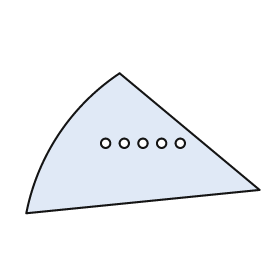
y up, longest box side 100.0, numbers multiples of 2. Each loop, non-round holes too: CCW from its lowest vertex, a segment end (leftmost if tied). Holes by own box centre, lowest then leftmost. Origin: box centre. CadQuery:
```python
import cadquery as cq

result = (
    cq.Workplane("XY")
    .moveTo(-50.0, -30.0)
    .lineTo(50.0, -20.0)
    .lineTo(-10.0, 30.0)
    .threePointArc((-36.0, 4.0), (-50.0, -30.0))
    .close()
    .moveTo(-16.0, 0.0)
    .circle(2.0)
    .moveTo(-8.0, 0.0)
    .circle(2.0)
    .moveTo(0.0, 0.0)
    .circle(2.0)
    .moveTo(8.0, 0.0)
    .circle(2.0)
    .moveTo(16.0, 0.0)
    .circle(2.0)
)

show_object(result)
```